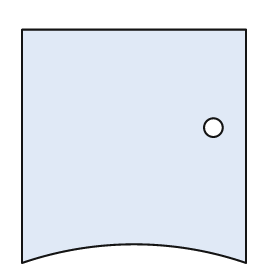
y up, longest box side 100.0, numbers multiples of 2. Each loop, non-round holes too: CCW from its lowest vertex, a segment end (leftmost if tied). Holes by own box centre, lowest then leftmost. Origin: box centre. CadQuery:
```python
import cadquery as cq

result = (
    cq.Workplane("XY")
    .moveTo(-48.0, -50.0)
    .threePointArc((0.0, -42.0), (48.0, -50.0))
    .lineTo(48.0, 50.0)
    .lineTo(-48.0, 50.0)
    .close()
    .moveTo(34.0, 8.0)
    .circle(4.0)
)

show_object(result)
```